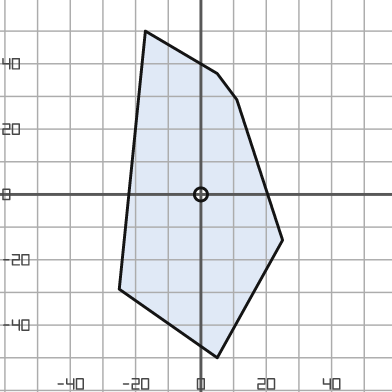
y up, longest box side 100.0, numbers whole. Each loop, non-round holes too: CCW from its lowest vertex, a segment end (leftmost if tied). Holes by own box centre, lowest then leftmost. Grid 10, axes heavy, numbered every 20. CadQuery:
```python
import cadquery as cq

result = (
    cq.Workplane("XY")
    .moveTo(5.0, -50.0)
    .lineTo(25.0, -14.0)
    .lineTo(11.0, 29.0)
    .lineTo(5.0, 37.0)
    .lineTo(-17.0, 50.0)
    .lineTo(-25.0, -29.0)
    .close()
    .moveTo(0.0, 0.0)
    .circle(2.0)
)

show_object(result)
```